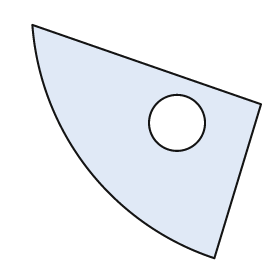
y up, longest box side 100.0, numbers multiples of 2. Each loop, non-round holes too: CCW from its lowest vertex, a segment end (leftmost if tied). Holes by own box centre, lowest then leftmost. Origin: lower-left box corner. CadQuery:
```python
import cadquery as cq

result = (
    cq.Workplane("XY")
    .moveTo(78.0, 0.0)
    .lineTo(98.0, 66.0)
    .lineTo(0.0, 100.0)
    .threePointArc((24.0, 38.0), (78.0, 0.0))
    .close()
    .moveTo(62.0, 58.0)
    .circle(12.0)
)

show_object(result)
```